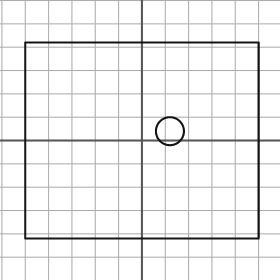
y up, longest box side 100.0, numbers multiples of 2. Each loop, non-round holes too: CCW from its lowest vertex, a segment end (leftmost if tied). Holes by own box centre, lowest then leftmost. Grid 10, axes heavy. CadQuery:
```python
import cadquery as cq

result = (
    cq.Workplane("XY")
    .moveTo(-50.0, -42.0)
    .lineTo(50.0, -42.0)
    .lineTo(50.0, 42.0)
    .lineTo(-50.0, 42.0)
    .close()
    .moveTo(12.0, 4.0)
    .circle(6.0)
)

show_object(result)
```